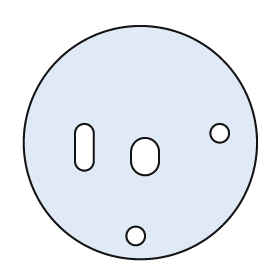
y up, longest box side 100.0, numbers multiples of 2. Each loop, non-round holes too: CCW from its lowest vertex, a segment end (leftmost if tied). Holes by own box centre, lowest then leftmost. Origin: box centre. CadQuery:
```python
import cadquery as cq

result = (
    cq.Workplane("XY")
    .moveTo(0.0, 0.0)
    .circle(50.0)
    .moveTo(-2.0, -40.0)
    .circle(4.0)
    .moveTo(-4.0, -8.0)
    .threePointArc((2.0, -14.0), (8.0, -8.0))
    .lineTo(8.0, -4.0)
    .threePointArc((2.0, 2.0), (-4.0, -4.0))
    .close()
    .moveTo(-28.0, -8.0)
    .threePointArc((-24.0, -12.0), (-20.0, -8.0))
    .lineTo(-20.0, 4.0)
    .threePointArc((-24.0, 8.0), (-28.0, 4.0))
    .close()
    .moveTo(34.0, 4.0)
    .circle(4.0)
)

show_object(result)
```